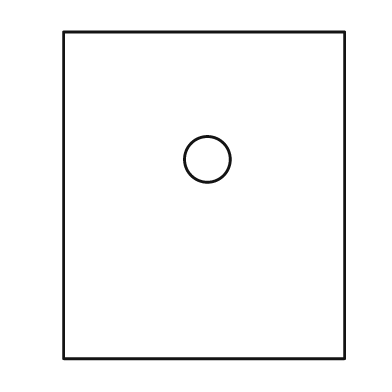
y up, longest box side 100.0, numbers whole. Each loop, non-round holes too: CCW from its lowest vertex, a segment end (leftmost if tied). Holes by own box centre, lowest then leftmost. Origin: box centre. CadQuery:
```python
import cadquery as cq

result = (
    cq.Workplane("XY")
    .moveTo(-43.0, -50.0)
    .lineTo(43.0, -50.0)
    .lineTo(43.0, 50.0)
    .lineTo(-43.0, 50.0)
    .close()
    .moveTo(1.0, 11.0)
    .circle(7.0)
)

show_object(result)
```